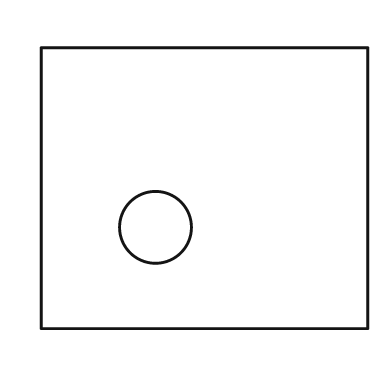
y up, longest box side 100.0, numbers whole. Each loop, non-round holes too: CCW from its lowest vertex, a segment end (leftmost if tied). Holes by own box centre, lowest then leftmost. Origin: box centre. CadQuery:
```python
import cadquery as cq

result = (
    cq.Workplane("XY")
    .moveTo(-50.0, -43.0)
    .lineTo(50.0, -43.0)
    .lineTo(50.0, 43.0)
    .lineTo(-50.0, 43.0)
    .close()
    .moveTo(-15.0, -12.0)
    .circle(11.0)
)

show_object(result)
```